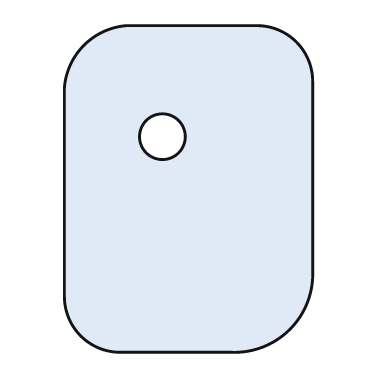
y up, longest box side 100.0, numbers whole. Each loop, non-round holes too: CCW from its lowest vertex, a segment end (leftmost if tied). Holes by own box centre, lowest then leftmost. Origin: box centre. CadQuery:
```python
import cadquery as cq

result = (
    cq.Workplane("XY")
    .moveTo(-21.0, -50.0)
    .lineTo(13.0, -50.0)
    .threePointArc((31.0, -43.0), (38.0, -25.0))
    .lineTo(38.0, 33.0)
    .threePointArc((33.0, 45.0), (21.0, 50.0))
    .lineTo(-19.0, 50.0)
    .threePointArc((-32.0, 44.0), (-38.0, 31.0))
    .lineTo(-38.0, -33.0)
    .threePointArc((-33.0, -45.0), (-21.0, -50.0))
    .close()
    .moveTo(-8.0, 16.0)
    .circle(7.0)
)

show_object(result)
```